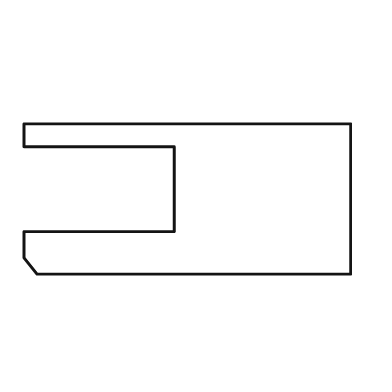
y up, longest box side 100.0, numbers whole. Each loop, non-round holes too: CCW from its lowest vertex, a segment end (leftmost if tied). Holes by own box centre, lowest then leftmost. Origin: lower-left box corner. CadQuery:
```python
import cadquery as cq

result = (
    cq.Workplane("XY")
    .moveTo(4.0, 0.0)
    .lineTo(100.0, 0.0)
    .lineTo(100.0, 46.0)
    .lineTo(0.0, 46.0)
    .lineTo(0.0, 39.0)
    .lineTo(46.0, 39.0)
    .lineTo(46.0, 13.0)
    .lineTo(0.0, 13.0)
    .lineTo(0.0, 5.0)
    .close()
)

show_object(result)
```